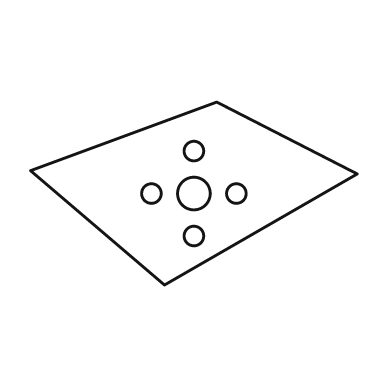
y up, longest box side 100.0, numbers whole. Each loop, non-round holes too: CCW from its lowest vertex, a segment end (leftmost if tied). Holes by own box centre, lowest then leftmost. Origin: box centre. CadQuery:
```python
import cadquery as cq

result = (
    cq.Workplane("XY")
    .moveTo(-9.0, -28.0)
    .lineTo(50.0, 6.0)
    .lineTo(7.0, 28.0)
    .lineTo(-50.0, 7.0)
    .close()
    .moveTo(0.0, -13.0)
    .circle(3.0)
    .moveTo(-13.0, 0.0)
    .circle(3.0)
    .moveTo(0.0, 0.0)
    .circle(5.0)
    .moveTo(13.0, 0.0)
    .circle(3.0)
    .moveTo(0.0, 13.0)
    .circle(3.0)
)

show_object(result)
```